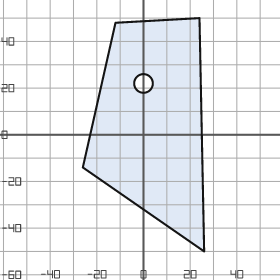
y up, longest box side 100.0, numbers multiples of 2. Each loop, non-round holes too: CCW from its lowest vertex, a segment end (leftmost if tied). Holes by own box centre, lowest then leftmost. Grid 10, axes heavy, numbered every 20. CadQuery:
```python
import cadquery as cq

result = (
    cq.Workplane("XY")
    .moveTo(26.0, -50.0)
    .lineTo(24.0, 50.0)
    .lineTo(-12.0, 48.0)
    .lineTo(-26.0, -14.0)
    .close()
    .moveTo(0.0, 22.0)
    .circle(4.0)
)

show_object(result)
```